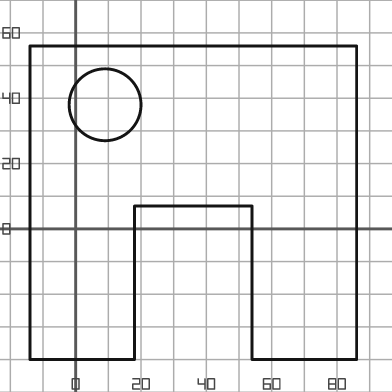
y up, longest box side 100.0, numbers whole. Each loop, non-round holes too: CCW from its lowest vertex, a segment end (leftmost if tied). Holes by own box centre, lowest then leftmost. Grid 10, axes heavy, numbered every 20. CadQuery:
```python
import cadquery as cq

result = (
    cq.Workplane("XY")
    .moveTo(-14.0, -40.0)
    .lineTo(18.0, -40.0)
    .lineTo(18.0, 7.0)
    .lineTo(54.0, 7.0)
    .lineTo(54.0, -40.0)
    .lineTo(86.0, -40.0)
    .lineTo(86.0, 56.0)
    .lineTo(-14.0, 56.0)
    .close()
    .moveTo(9.0, 38.0)
    .circle(11.0)
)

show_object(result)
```